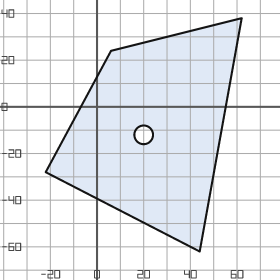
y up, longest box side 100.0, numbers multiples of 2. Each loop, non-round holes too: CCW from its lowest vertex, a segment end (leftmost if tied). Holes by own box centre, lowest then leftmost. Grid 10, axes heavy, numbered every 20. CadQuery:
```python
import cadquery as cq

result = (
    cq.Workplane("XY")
    .moveTo(44.0, -62.0)
    .lineTo(62.0, 38.0)
    .lineTo(6.0, 24.0)
    .lineTo(-22.0, -28.0)
    .close()
    .moveTo(20.0, -12.0)
    .circle(4.0)
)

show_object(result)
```